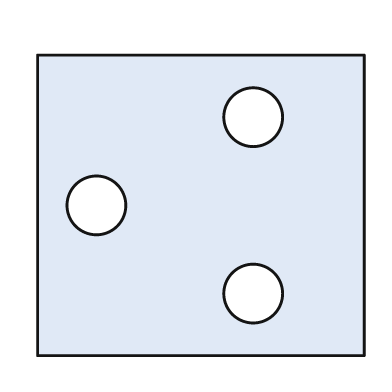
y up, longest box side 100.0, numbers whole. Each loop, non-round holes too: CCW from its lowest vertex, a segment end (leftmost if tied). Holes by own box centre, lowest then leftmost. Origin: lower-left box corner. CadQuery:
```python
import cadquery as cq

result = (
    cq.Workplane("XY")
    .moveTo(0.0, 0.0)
    .lineTo(100.0, 0.0)
    .lineTo(100.0, 92.0)
    .lineTo(0.0, 92.0)
    .close()
    .moveTo(66.0, 19.0)
    .circle(9.0)
    .moveTo(18.0, 46.0)
    .circle(9.0)
    .moveTo(66.0, 73.0)
    .circle(9.0)
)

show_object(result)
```